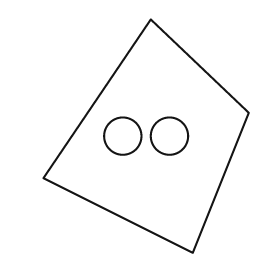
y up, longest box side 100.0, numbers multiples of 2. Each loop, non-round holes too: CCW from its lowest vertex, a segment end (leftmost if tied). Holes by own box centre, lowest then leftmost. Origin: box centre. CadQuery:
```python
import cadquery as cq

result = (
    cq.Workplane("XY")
    .moveTo(20.0, -50.0)
    .lineTo(44.0, 10.0)
    .lineTo(2.0, 50.0)
    .lineTo(-44.0, -18.0)
    .close()
    .moveTo(-10.0, 0.0)
    .circle(8.0)
    .moveTo(10.0, 0.0)
    .circle(8.0)
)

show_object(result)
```